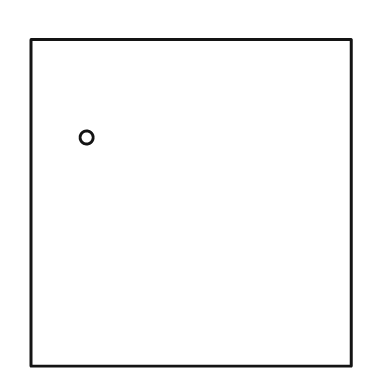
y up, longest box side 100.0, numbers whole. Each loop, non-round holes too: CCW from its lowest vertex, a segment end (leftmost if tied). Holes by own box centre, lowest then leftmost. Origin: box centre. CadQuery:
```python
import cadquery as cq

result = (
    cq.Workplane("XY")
    .moveTo(-49.0, -50.0)
    .lineTo(49.0, -50.0)
    .lineTo(49.0, 50.0)
    .lineTo(-49.0, 50.0)
    .close()
    .moveTo(-32.0, 20.0)
    .circle(2.0)
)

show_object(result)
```